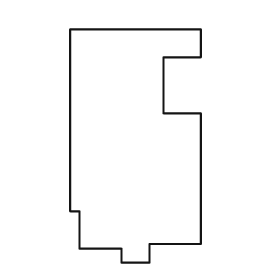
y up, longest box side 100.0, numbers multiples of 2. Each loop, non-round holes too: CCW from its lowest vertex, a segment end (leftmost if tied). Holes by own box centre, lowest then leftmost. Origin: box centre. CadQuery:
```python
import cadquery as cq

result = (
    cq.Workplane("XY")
    .moveTo(-6.0, -50.0)
    .lineTo(6.0, -50.0)
    .lineTo(6.0, -42.0)
    .lineTo(28.0, -42.0)
    .lineTo(28.0, 14.0)
    .lineTo(12.0, 14.0)
    .lineTo(12.0, 38.0)
    .lineTo(28.0, 38.0)
    .lineTo(28.0, 50.0)
    .lineTo(-28.0, 50.0)
    .lineTo(-28.0, -28.0)
    .lineTo(-24.0, -28.0)
    .lineTo(-24.0, -44.0)
    .lineTo(-6.0, -44.0)
    .close()
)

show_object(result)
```